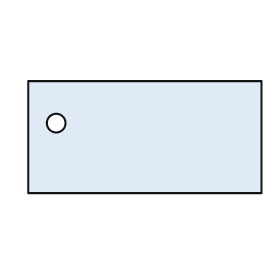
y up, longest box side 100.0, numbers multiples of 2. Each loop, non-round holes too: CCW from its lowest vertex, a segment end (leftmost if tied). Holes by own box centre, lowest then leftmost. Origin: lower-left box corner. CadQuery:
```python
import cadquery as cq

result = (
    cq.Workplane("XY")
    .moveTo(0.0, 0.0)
    .lineTo(100.0, 0.0)
    .lineTo(100.0, 48.0)
    .lineTo(0.0, 48.0)
    .close()
    .moveTo(12.0, 30.0)
    .circle(4.0)
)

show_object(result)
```